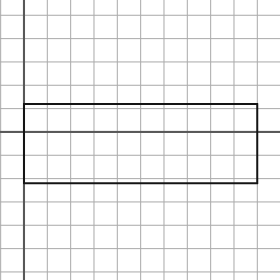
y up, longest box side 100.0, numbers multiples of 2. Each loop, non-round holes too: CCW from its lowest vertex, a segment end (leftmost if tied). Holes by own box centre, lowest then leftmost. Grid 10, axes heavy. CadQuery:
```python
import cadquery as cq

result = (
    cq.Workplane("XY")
    .moveTo(0.0, -22.0)
    .lineTo(100.0, -22.0)
    .lineTo(100.0, 12.0)
    .lineTo(0.0, 12.0)
    .close()
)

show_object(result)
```